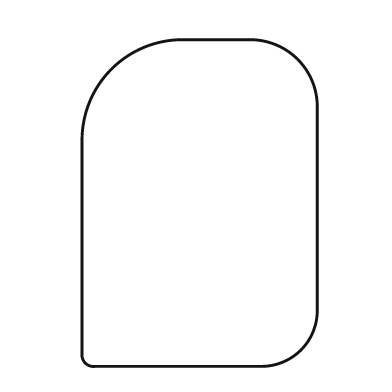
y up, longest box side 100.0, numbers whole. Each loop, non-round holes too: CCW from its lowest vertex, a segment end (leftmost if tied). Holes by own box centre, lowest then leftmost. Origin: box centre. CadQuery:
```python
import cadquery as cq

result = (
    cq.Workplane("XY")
    .moveTo(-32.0, -50.0)
    .lineTo(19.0, -50.0)
    .threePointArc((31.0, -45.0), (36.0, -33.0))
    .lineTo(36.0, 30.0)
    .threePointArc((30.0, 44.0), (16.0, 50.0))
    .lineTo(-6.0, 50.0)
    .threePointArc((-27.0, 41.0), (-36.0, 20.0))
    .lineTo(-36.0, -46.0)
    .threePointArc((-35.0, -49.0), (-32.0, -50.0))
    .close()
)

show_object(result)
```